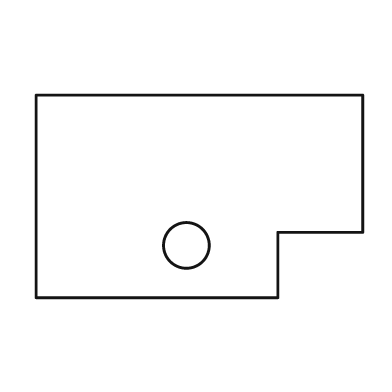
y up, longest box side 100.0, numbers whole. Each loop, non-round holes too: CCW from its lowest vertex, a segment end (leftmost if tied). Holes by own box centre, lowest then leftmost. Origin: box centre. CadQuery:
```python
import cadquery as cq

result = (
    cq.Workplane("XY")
    .moveTo(-50.0, -31.0)
    .lineTo(24.0, -31.0)
    .lineTo(24.0, -11.0)
    .lineTo(50.0, -11.0)
    .lineTo(50.0, 31.0)
    .lineTo(-50.0, 31.0)
    .close()
    .moveTo(-4.0, -15.0)
    .circle(7.0)
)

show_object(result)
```